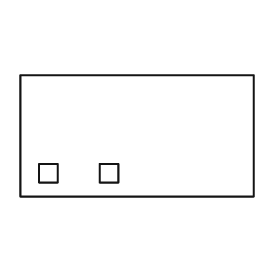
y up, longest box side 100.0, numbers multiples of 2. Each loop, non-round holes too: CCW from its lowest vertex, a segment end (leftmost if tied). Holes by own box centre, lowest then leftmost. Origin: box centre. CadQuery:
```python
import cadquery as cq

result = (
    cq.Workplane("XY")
    .moveTo(-50.0, -26.0)
    .lineTo(50.0, -26.0)
    .lineTo(50.0, 26.0)
    .lineTo(-50.0, 26.0)
    .close()
    .moveTo(-42.0, -20.0)
    .lineTo(-34.0, -20.0)
    .lineTo(-34.0, -12.0)
    .lineTo(-42.0, -12.0)
    .close()
    .moveTo(-16.0, -20.0)
    .lineTo(-8.0, -20.0)
    .lineTo(-8.0, -12.0)
    .lineTo(-16.0, -12.0)
    .close()
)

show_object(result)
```